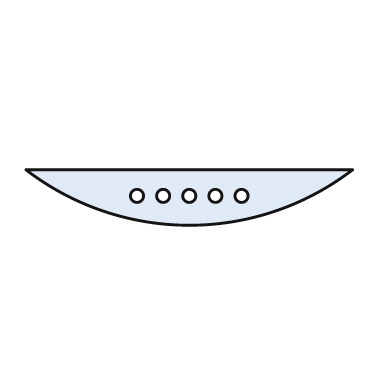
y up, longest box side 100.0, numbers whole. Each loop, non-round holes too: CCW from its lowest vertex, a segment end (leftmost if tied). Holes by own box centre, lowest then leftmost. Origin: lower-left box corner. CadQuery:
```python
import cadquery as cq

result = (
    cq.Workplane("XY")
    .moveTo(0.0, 17.0)
    .threePointArc((50.0, 0.0), (100.0, 17.0))
    .close()
    .moveTo(34.0, 9.0)
    .circle(2.0)
    .moveTo(42.0, 9.0)
    .circle(2.0)
    .moveTo(50.0, 9.0)
    .circle(2.0)
    .moveTo(58.0, 9.0)
    .circle(2.0)
    .moveTo(66.0, 9.0)
    .circle(2.0)
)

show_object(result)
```